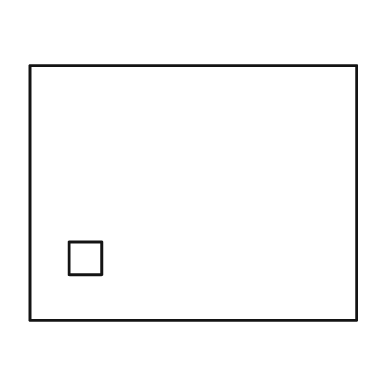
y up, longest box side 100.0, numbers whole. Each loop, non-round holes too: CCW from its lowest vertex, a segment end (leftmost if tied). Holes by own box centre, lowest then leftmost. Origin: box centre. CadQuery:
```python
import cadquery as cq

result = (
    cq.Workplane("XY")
    .moveTo(-50.0, -39.0)
    .lineTo(50.0, -39.0)
    .lineTo(50.0, 39.0)
    .lineTo(-50.0, 39.0)
    .close()
    .moveTo(-38.0, -25.0)
    .lineTo(-28.0, -25.0)
    .lineTo(-28.0, -15.0)
    .lineTo(-38.0, -15.0)
    .close()
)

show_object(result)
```